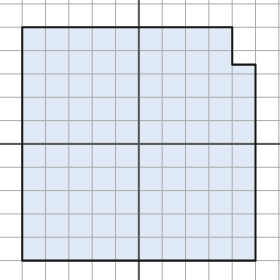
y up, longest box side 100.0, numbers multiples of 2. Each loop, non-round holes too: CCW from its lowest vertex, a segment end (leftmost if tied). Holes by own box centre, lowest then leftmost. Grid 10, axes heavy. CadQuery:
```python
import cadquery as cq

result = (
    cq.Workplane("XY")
    .moveTo(-50.0, -50.0)
    .lineTo(50.0, -50.0)
    .lineTo(50.0, 34.0)
    .lineTo(40.0, 34.0)
    .lineTo(40.0, 50.0)
    .lineTo(-50.0, 50.0)
    .close()
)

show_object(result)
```